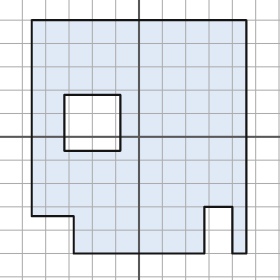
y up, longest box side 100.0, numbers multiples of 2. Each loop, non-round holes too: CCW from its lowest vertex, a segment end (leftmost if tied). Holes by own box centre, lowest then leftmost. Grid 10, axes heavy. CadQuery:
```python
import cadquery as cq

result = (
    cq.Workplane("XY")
    .moveTo(-28.0, -50.0)
    .lineTo(28.0, -50.0)
    .lineTo(28.0, -30.0)
    .lineTo(40.0, -30.0)
    .lineTo(40.0, -50.0)
    .lineTo(46.0, -50.0)
    .lineTo(46.0, 50.0)
    .lineTo(-46.0, 50.0)
    .lineTo(-46.0, -34.0)
    .lineTo(-28.0, -34.0)
    .close()
    .moveTo(-32.0, -6.0)
    .lineTo(-8.0, -6.0)
    .lineTo(-8.0, 18.0)
    .lineTo(-32.0, 18.0)
    .close()
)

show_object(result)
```